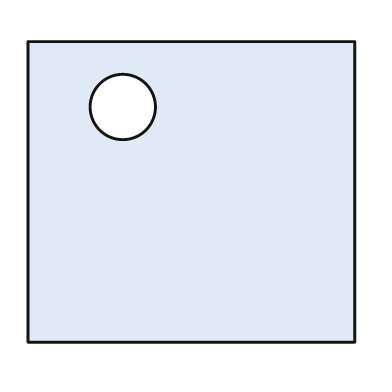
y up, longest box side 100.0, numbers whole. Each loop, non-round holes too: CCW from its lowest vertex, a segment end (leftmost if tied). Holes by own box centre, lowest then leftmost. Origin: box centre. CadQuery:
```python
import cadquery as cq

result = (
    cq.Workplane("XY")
    .moveTo(-50.0, -46.0)
    .lineTo(50.0, -46.0)
    .lineTo(50.0, 46.0)
    .lineTo(-50.0, 46.0)
    .close()
    .moveTo(-21.0, 26.0)
    .circle(10.0)
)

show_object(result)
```